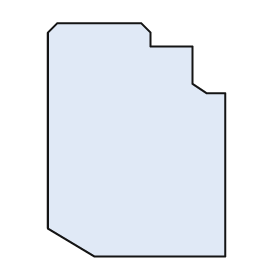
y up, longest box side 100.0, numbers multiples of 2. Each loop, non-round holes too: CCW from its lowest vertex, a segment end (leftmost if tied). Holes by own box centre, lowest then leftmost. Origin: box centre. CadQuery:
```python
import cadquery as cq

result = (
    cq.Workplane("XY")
    .moveTo(-18.0, -50.0)
    .lineTo(38.0, -50.0)
    .lineTo(38.0, 20.0)
    .lineTo(30.0, 20.0)
    .lineTo(24.0, 24.0)
    .lineTo(24.0, 40.0)
    .lineTo(6.0, 40.0)
    .lineTo(6.0, 46.0)
    .lineTo(2.0, 50.0)
    .lineTo(-34.0, 50.0)
    .lineTo(-38.0, 46.0)
    .lineTo(-38.0, -38.0)
    .close()
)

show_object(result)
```